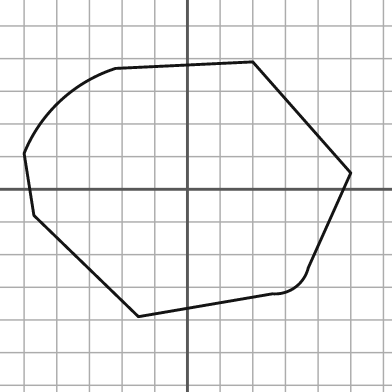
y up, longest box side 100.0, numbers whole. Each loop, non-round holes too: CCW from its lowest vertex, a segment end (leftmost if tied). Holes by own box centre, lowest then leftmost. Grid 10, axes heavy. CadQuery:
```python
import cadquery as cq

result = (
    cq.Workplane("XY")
    .moveTo(-15.0, -39.0)
    .lineTo(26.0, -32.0)
    .threePointArc((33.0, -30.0), (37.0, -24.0))
    .lineTo(50.0, 5.0)
    .lineTo(20.0, 39.0)
    .lineTo(-22.0, 37.0)
    .threePointArc((-39.0, 27.0), (-50.0, 11.0))
    .lineTo(-47.0, -8.0)
    .close()
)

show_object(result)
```